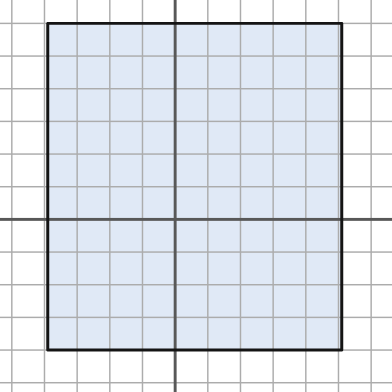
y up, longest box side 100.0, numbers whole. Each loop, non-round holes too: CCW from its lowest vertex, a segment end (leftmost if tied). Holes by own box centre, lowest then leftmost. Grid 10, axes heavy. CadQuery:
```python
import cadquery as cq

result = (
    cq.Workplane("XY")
    .moveTo(-39.0, -40.0)
    .lineTo(51.0, -40.0)
    .lineTo(51.0, 60.0)
    .lineTo(-39.0, 60.0)
    .close()
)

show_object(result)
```